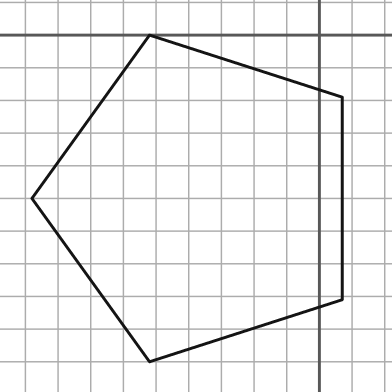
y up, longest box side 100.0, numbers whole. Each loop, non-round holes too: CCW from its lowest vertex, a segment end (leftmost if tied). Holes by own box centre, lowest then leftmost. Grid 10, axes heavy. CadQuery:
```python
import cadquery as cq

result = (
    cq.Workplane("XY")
    .moveTo(-52.0, -100.0)
    .lineTo(7.0, -81.0)
    .lineTo(7.0, -19.0)
    .lineTo(-52.0, 0.0)
    .lineTo(-88.0, -50.0)
    .close()
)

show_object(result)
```